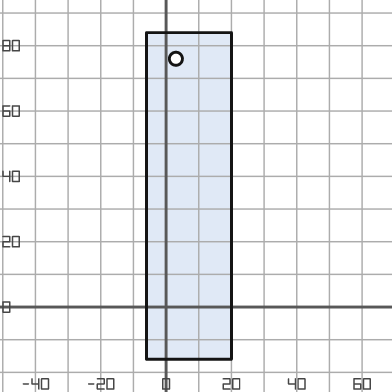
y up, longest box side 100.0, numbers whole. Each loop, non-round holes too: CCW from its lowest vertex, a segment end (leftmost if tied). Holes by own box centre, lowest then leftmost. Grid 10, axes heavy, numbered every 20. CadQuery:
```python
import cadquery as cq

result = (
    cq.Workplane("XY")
    .moveTo(-6.0, -16.0)
    .lineTo(20.0, -16.0)
    .lineTo(20.0, 84.0)
    .lineTo(-6.0, 84.0)
    .close()
    .moveTo(3.0, 76.0)
    .circle(2.0)
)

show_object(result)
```